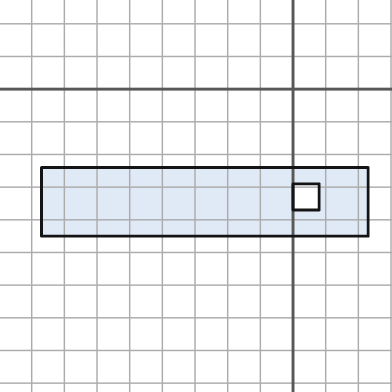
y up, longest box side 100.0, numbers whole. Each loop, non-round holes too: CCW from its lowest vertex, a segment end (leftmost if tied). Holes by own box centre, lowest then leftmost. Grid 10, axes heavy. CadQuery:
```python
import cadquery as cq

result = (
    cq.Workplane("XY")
    .moveTo(-77.0, -45.0)
    .lineTo(23.0, -45.0)
    .lineTo(23.0, -24.0)
    .lineTo(-77.0, -24.0)
    .close()
    .moveTo(0.0, -37.0)
    .lineTo(8.0, -37.0)
    .lineTo(8.0, -29.0)
    .lineTo(0.0, -29.0)
    .close()
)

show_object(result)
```